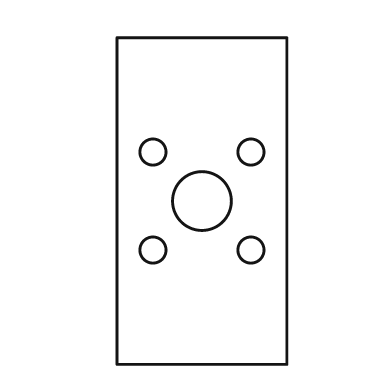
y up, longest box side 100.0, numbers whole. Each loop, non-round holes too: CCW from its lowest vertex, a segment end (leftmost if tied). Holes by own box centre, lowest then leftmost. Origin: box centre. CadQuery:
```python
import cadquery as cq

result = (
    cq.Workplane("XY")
    .moveTo(-26.0, -50.0)
    .lineTo(26.0, -50.0)
    .lineTo(26.0, 50.0)
    .lineTo(-26.0, 50.0)
    .close()
    .moveTo(-15.0, -15.0)
    .circle(4.0)
    .moveTo(15.0, -15.0)
    .circle(4.0)
    .moveTo(0.0, 0.0)
    .circle(9.0)
    .moveTo(-15.0, 15.0)
    .circle(4.0)
    .moveTo(15.0, 15.0)
    .circle(4.0)
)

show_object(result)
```